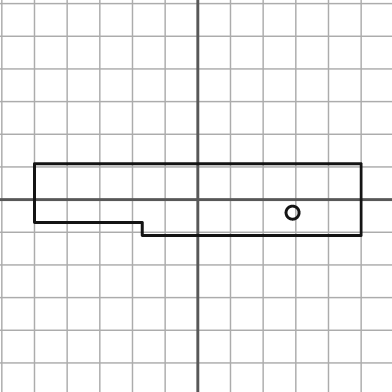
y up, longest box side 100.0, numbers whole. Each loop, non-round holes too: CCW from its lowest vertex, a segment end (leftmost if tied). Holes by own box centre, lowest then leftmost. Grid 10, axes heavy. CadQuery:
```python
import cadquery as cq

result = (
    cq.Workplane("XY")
    .moveTo(-17.0, -11.0)
    .lineTo(50.0, -11.0)
    .lineTo(50.0, 11.0)
    .lineTo(-50.0, 11.0)
    .lineTo(-50.0, -7.0)
    .lineTo(-17.0, -7.0)
    .close()
    .moveTo(29.0, -4.0)
    .circle(2.0)
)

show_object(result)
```